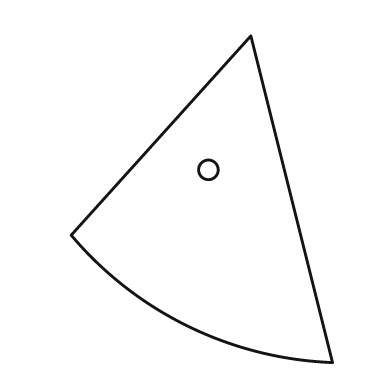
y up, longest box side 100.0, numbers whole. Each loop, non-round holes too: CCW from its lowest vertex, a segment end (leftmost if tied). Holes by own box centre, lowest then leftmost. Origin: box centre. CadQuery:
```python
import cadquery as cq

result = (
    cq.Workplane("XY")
    .moveTo(40.0, -50.0)
    .lineTo(15.0, 50.0)
    .lineTo(-40.0, -11.0)
    .threePointArc((-4.0, -39.0), (40.0, -50.0))
    .close()
    .moveTo(2.0, 9.0)
    .circle(3.0)
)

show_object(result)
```